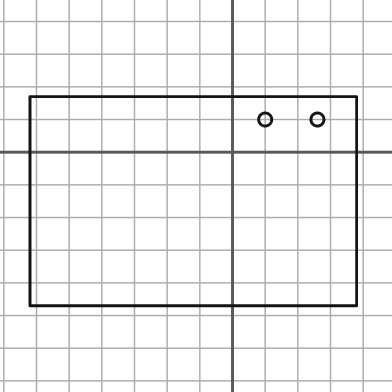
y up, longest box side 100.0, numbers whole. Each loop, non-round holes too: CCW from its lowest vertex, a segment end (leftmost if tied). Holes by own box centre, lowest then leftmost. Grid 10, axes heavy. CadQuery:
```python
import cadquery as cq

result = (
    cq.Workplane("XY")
    .moveTo(-62.0, -47.0)
    .lineTo(38.0, -47.0)
    .lineTo(38.0, 17.0)
    .lineTo(-62.0, 17.0)
    .close()
    .moveTo(10.0, 10.0)
    .circle(2.0)
    .moveTo(26.0, 10.0)
    .circle(2.0)
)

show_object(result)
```